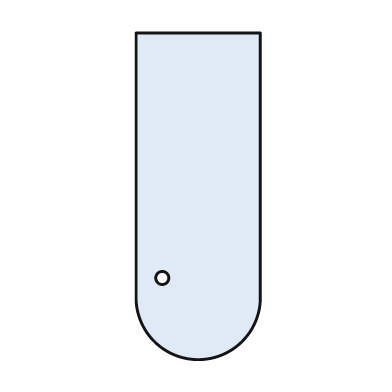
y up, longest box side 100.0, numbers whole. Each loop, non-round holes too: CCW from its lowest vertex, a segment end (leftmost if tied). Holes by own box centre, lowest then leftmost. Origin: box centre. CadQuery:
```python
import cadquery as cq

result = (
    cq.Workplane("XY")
    .moveTo(-19.0, -32.0)
    .threePointArc((0.0, -50.0), (19.0, -32.0))
    .lineTo(19.0, 50.0)
    .lineTo(-19.0, 50.0)
    .close()
    .moveTo(-11.0, -25.0)
    .circle(2.0)
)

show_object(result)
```